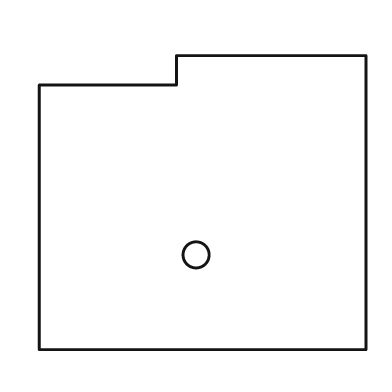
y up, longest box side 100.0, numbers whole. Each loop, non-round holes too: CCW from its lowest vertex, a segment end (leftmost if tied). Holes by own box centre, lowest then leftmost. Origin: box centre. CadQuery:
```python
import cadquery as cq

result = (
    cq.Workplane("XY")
    .moveTo(-50.0, -45.0)
    .lineTo(50.0, -45.0)
    .lineTo(50.0, 45.0)
    .lineTo(-8.0, 45.0)
    .lineTo(-8.0, 36.0)
    .lineTo(-50.0, 36.0)
    .close()
    .moveTo(-2.0, -16.0)
    .circle(4.0)
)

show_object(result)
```